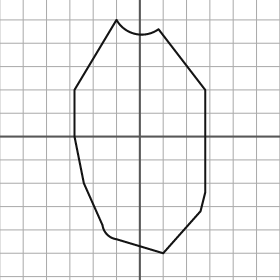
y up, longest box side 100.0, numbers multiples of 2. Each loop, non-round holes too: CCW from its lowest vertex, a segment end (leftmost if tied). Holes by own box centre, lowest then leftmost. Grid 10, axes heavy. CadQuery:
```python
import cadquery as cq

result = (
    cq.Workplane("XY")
    .moveTo(10.0, -50.0)
    .lineTo(26.0, -32.0)
    .lineTo(28.0, -24.0)
    .lineTo(28.0, 20.0)
    .lineTo(8.0, 46.0)
    .threePointArc((-2.0, 44.0), (-10.0, 50.0))
    .lineTo(-28.0, 20.0)
    .lineTo(-28.0, 0.0)
    .lineTo(-24.0, -20.0)
    .lineTo(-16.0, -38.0)
    .threePointArc((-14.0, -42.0), (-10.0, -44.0))
    .close()
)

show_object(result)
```